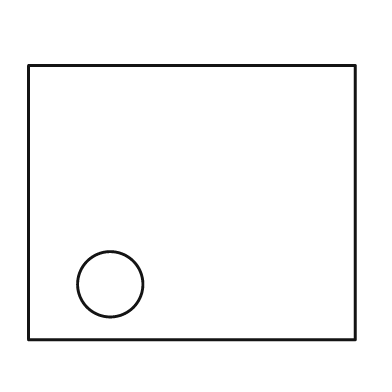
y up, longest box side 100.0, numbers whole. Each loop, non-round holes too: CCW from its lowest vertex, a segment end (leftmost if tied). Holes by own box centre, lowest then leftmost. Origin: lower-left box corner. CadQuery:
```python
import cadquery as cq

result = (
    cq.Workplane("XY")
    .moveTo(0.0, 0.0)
    .lineTo(100.0, 0.0)
    .lineTo(100.0, 84.0)
    .lineTo(0.0, 84.0)
    .close()
    .moveTo(25.0, 17.0)
    .circle(10.0)
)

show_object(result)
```